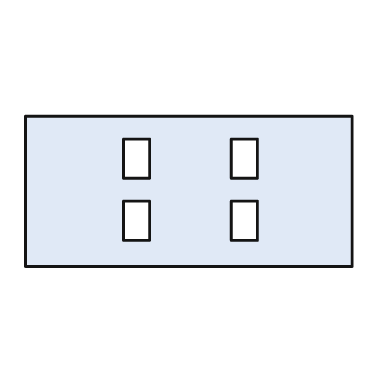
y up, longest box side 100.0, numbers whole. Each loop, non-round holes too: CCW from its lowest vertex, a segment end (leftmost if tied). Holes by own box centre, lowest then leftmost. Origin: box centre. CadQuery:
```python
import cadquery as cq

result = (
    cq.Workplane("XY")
    .moveTo(-50.0, -23.0)
    .lineTo(50.0, -23.0)
    .lineTo(50.0, 23.0)
    .lineTo(-50.0, 23.0)
    .close()
    .moveTo(-20.0, -15.0)
    .lineTo(-12.0, -15.0)
    .lineTo(-12.0, -3.0)
    .lineTo(-20.0, -3.0)
    .close()
    .moveTo(13.0, -15.0)
    .lineTo(21.0, -15.0)
    .lineTo(21.0, -3.0)
    .lineTo(13.0, -3.0)
    .close()
    .moveTo(-20.0, 4.0)
    .lineTo(-12.0, 4.0)
    .lineTo(-12.0, 16.0)
    .lineTo(-20.0, 16.0)
    .close()
    .moveTo(13.0, 4.0)
    .lineTo(21.0, 4.0)
    .lineTo(21.0, 16.0)
    .lineTo(13.0, 16.0)
    .close()
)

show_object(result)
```